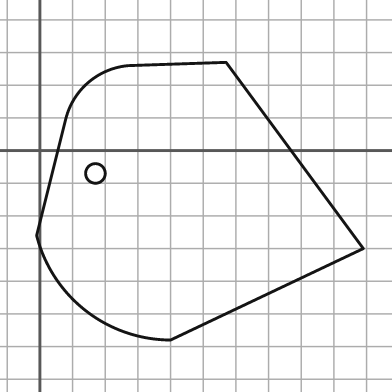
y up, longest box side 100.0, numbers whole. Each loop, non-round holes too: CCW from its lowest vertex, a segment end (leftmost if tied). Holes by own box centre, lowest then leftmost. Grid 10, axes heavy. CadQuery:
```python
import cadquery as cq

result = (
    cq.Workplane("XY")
    .moveTo(40.0, -58.0)
    .lineTo(99.0, -30.0)
    .lineTo(57.0, 27.0)
    .lineTo(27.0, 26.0)
    .threePointArc((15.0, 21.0), (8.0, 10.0))
    .lineTo(-1.0, -26.0)
    .threePointArc((14.0, -49.0), (40.0, -58.0))
    .close()
    .moveTo(17.0, -7.0)
    .circle(3.0)
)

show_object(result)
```